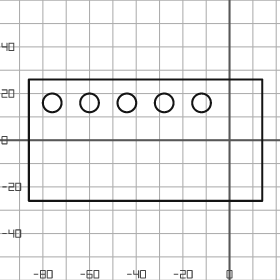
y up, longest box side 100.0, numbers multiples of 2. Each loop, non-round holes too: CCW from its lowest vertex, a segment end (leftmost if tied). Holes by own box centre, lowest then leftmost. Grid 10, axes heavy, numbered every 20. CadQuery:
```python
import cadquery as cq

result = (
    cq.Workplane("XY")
    .moveTo(-86.0, -26.0)
    .lineTo(14.0, -26.0)
    .lineTo(14.0, 26.0)
    .lineTo(-86.0, 26.0)
    .close()
    .moveTo(-76.0, 16.0)
    .circle(4.0)
    .moveTo(-60.0, 16.0)
    .circle(4.0)
    .moveTo(-44.0, 16.0)
    .circle(4.0)
    .moveTo(-28.0, 16.0)
    .circle(4.0)
    .moveTo(-12.0, 16.0)
    .circle(4.0)
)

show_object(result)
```